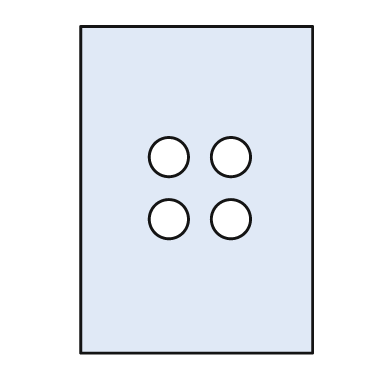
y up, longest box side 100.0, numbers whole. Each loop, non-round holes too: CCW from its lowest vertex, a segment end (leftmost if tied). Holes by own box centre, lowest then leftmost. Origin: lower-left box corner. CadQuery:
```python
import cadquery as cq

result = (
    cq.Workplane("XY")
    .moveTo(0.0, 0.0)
    .lineTo(71.0, 0.0)
    .lineTo(71.0, 100.0)
    .lineTo(0.0, 100.0)
    .close()
    .moveTo(27.0, 41.0)
    .circle(6.0)
    .moveTo(46.0, 41.0)
    .circle(6.0)
    .moveTo(27.0, 60.0)
    .circle(6.0)
    .moveTo(46.0, 60.0)
    .circle(6.0)
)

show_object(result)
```